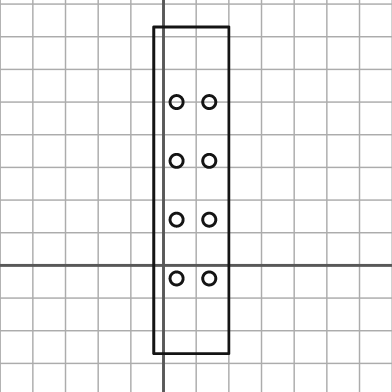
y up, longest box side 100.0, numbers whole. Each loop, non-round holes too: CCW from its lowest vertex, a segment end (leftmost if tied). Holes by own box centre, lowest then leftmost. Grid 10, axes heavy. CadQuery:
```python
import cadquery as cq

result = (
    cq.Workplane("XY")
    .moveTo(-3.0, -27.0)
    .lineTo(20.0, -27.0)
    .lineTo(20.0, 73.0)
    .lineTo(-3.0, 73.0)
    .close()
    .moveTo(4.0, -4.0)
    .circle(2.0)
    .moveTo(14.0, -4.0)
    .circle(2.0)
    .moveTo(4.0, 14.0)
    .circle(2.0)
    .moveTo(14.0, 14.0)
    .circle(2.0)
    .moveTo(4.0, 32.0)
    .circle(2.0)
    .moveTo(14.0, 32.0)
    .circle(2.0)
    .moveTo(4.0, 50.0)
    .circle(2.0)
    .moveTo(14.0, 50.0)
    .circle(2.0)
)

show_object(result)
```